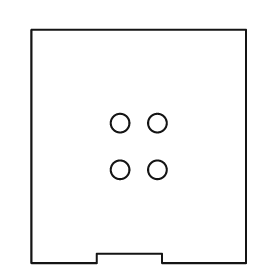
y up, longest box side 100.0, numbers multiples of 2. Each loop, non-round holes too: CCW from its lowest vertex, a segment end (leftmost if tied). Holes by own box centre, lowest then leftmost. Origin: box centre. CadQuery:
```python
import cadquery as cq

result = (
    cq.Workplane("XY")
    .moveTo(-46.0, -50.0)
    .lineTo(-18.0, -50.0)
    .lineTo(-18.0, -46.0)
    .lineTo(10.0, -46.0)
    .lineTo(10.0, -50.0)
    .lineTo(46.0, -50.0)
    .lineTo(46.0, 50.0)
    .lineTo(-46.0, 50.0)
    .close()
    .moveTo(-8.0, -10.0)
    .circle(4.0)
    .moveTo(8.0, -10.0)
    .circle(4.0)
    .moveTo(-8.0, 10.0)
    .circle(4.0)
    .moveTo(8.0, 10.0)
    .circle(4.0)
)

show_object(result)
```